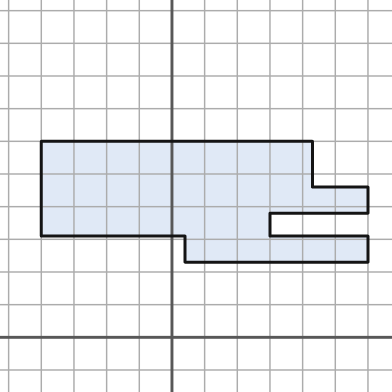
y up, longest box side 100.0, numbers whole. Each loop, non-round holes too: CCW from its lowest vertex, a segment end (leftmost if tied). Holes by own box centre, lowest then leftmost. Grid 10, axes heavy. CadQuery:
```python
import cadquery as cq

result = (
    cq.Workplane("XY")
    .moveTo(4.0, 23.0)
    .lineTo(60.0, 23.0)
    .lineTo(60.0, 31.0)
    .lineTo(30.0, 31.0)
    .lineTo(30.0, 38.0)
    .lineTo(60.0, 38.0)
    .lineTo(60.0, 46.0)
    .lineTo(43.0, 46.0)
    .lineTo(43.0, 60.0)
    .lineTo(-40.0, 60.0)
    .lineTo(-40.0, 31.0)
    .lineTo(4.0, 31.0)
    .close()
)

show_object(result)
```